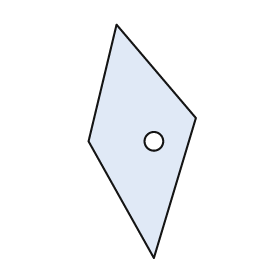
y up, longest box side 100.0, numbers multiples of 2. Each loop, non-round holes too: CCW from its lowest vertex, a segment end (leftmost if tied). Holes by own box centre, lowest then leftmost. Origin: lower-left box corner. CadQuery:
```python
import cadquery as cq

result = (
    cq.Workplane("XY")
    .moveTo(28.0, 0.0)
    .lineTo(46.0, 60.0)
    .lineTo(12.0, 100.0)
    .lineTo(0.0, 50.0)
    .close()
    .moveTo(28.0, 50.0)
    .circle(4.0)
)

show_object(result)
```